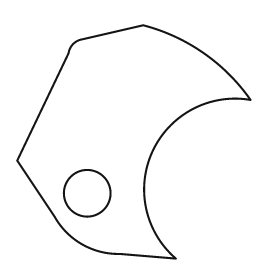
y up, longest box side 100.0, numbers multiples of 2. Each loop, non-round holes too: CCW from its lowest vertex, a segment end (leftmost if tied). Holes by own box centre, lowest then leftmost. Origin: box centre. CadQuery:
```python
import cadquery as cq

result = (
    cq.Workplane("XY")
    .moveTo(18.0, -50.0)
    .threePointArc((8.0, -4.0), (50.0, 18.0))
    .threePointArc((30.0, 38.0), (4.0, 50.0))
    .lineTo(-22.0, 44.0)
    .threePointArc((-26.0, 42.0), (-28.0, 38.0))
    .lineTo(-50.0, -8.0)
    .lineTo(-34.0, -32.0)
    .threePointArc((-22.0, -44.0), (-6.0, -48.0))
    .close()
    .moveTo(-20.0, -22.0)
    .circle(10.0)
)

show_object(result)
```